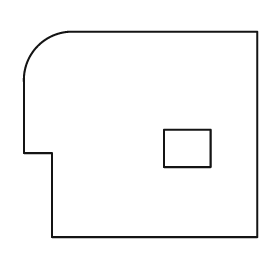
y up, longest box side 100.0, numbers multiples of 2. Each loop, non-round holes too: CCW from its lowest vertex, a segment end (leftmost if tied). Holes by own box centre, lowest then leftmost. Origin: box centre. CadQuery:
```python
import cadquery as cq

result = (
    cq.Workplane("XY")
    .moveTo(-38.0, -44.0)
    .lineTo(50.0, -44.0)
    .lineTo(50.0, 44.0)
    .lineTo(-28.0, 44.0)
    .threePointArc((-44.0, 38.0), (-50.0, 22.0))
    .lineTo(-50.0, -8.0)
    .lineTo(-38.0, -8.0)
    .close()
    .moveTo(10.0, -14.0)
    .lineTo(30.0, -14.0)
    .lineTo(30.0, 2.0)
    .lineTo(10.0, 2.0)
    .close()
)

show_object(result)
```